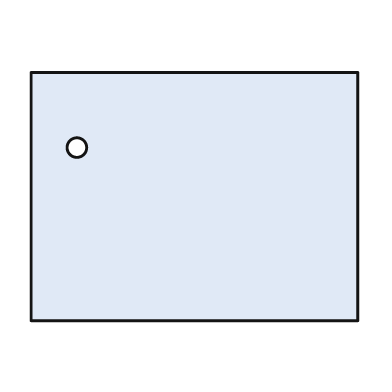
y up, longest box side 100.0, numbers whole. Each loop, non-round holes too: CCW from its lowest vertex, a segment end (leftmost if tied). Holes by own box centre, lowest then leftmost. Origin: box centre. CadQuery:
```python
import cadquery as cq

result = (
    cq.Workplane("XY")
    .moveTo(-50.0, -38.0)
    .lineTo(50.0, -38.0)
    .lineTo(50.0, 38.0)
    .lineTo(-50.0, 38.0)
    .close()
    .moveTo(-36.0, 15.0)
    .circle(3.0)
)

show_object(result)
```